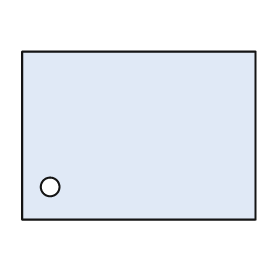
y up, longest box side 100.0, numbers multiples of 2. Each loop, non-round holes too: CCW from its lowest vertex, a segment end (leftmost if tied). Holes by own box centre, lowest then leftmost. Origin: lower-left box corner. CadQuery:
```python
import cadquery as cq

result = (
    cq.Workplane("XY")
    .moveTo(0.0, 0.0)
    .lineTo(100.0, 0.0)
    .lineTo(100.0, 72.0)
    .lineTo(0.0, 72.0)
    .close()
    .moveTo(12.0, 14.0)
    .circle(4.0)
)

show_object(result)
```